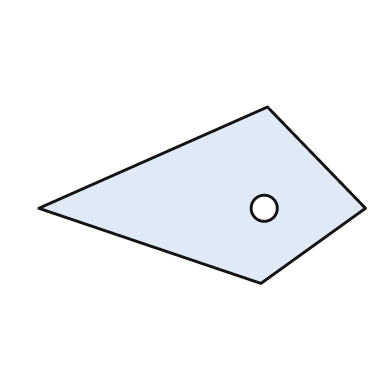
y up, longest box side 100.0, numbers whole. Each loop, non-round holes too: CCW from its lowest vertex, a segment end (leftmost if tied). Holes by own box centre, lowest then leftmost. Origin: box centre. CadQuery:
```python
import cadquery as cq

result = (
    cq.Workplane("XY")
    .moveTo(18.0, -27.0)
    .lineTo(50.0, -4.0)
    .lineTo(20.0, 27.0)
    .lineTo(-50.0, -4.0)
    .close()
    .moveTo(19.0, -4.0)
    .circle(4.0)
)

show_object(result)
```